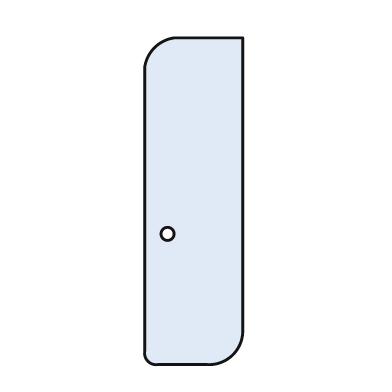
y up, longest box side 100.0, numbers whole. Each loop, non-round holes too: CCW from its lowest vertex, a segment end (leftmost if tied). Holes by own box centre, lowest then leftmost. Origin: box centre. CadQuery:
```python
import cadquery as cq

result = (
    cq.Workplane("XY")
    .moveTo(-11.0, -50.0)
    .lineTo(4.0, -50.0)
    .threePointArc((12.0, -47.0), (15.0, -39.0))
    .lineTo(15.0, 50.0)
    .lineTo(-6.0, 50.0)
    .threePointArc((-12.0, 47.0), (-15.0, 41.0))
    .lineTo(-15.0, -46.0)
    .threePointArc((-14.0, -49.0), (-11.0, -50.0))
    .close()
    .moveTo(-8.0, -10.0)
    .circle(2.0)
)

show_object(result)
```